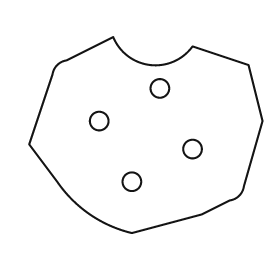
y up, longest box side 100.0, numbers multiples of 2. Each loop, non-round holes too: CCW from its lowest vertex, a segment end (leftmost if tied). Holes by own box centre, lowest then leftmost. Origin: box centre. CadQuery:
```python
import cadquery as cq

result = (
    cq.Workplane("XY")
    .moveTo(-6.0, -42.0)
    .lineTo(24.0, -34.0)
    .lineTo(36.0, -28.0)
    .threePointArc((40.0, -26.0), (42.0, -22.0))
    .lineTo(50.0, 6.0)
    .lineTo(44.0, 30.0)
    .lineTo(20.0, 38.0)
    .threePointArc((2.0, 30.0), (-14.0, 42.0))
    .lineTo(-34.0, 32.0)
    .threePointArc((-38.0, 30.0), (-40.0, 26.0))
    .lineTo(-50.0, -4.0)
    .lineTo(-38.0, -20.0)
    .threePointArc((-24.0, -34.0), (-6.0, -42.0))
    .close()
    .moveTo(-6.0, -20.0)
    .circle(4.0)
    .moveTo(20.0, -6.0)
    .circle(4.0)
    .moveTo(-20.0, 6.0)
    .circle(4.0)
    .moveTo(6.0, 20.0)
    .circle(4.0)
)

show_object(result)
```